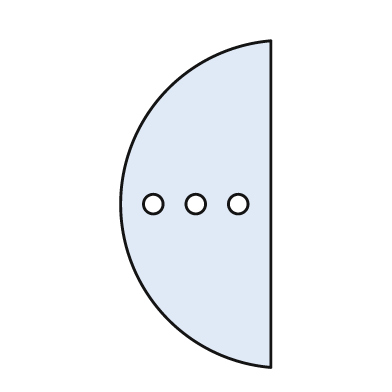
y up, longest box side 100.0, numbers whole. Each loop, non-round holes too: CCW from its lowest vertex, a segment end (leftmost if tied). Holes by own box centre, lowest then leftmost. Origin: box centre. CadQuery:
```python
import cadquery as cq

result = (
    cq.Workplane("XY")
    .moveTo(23.0, -50.0)
    .lineTo(23.0, 50.0)
    .threePointArc((-23.0, 0.0), (23.0, -50.0))
    .close()
    .moveTo(-13.0, 0.0)
    .circle(3.0)
    .moveTo(0.0, 0.0)
    .circle(3.0)
    .moveTo(13.0, 0.0)
    .circle(3.0)
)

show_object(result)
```